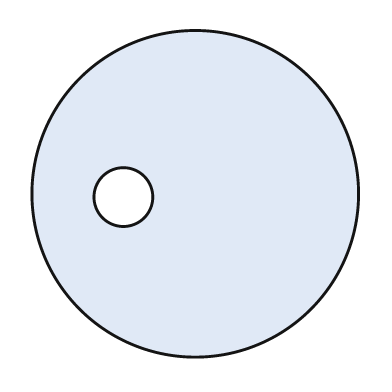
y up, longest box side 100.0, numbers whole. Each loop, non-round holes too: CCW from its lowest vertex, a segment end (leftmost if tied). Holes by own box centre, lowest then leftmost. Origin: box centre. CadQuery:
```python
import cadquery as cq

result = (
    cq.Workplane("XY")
    .moveTo(0.0, 0.0)
    .circle(50.0)
    .moveTo(-22.0, -1.0)
    .circle(9.0)
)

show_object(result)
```